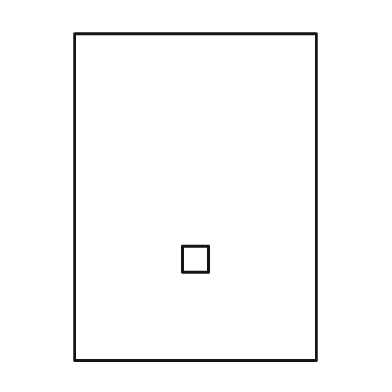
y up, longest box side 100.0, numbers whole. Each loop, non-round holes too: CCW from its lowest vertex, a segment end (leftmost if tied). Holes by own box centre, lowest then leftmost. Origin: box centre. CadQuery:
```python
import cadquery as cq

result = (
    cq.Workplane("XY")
    .moveTo(-37.0, -50.0)
    .lineTo(37.0, -50.0)
    .lineTo(37.0, 50.0)
    .lineTo(-37.0, 50.0)
    .close()
    .moveTo(-4.0, -23.0)
    .lineTo(4.0, -23.0)
    .lineTo(4.0, -15.0)
    .lineTo(-4.0, -15.0)
    .close()
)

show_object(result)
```